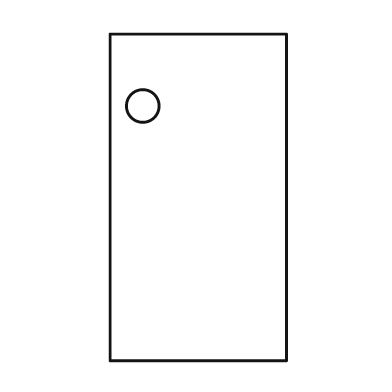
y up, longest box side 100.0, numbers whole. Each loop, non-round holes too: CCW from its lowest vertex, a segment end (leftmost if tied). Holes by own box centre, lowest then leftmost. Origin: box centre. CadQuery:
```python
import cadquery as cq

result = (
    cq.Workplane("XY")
    .moveTo(-27.0, -50.0)
    .lineTo(27.0, -50.0)
    .lineTo(27.0, 50.0)
    .lineTo(-27.0, 50.0)
    .close()
    .moveTo(-17.0, 28.0)
    .circle(5.0)
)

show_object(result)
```